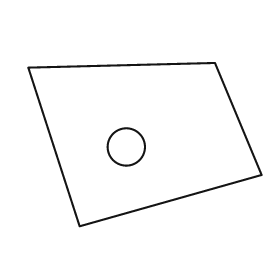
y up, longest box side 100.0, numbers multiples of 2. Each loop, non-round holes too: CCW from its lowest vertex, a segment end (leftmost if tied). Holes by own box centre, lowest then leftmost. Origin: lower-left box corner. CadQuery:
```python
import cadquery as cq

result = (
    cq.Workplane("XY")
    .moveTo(22.0, 0.0)
    .lineTo(100.0, 22.0)
    .lineTo(80.0, 70.0)
    .lineTo(0.0, 68.0)
    .close()
    .moveTo(42.0, 34.0)
    .circle(8.0)
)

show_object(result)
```